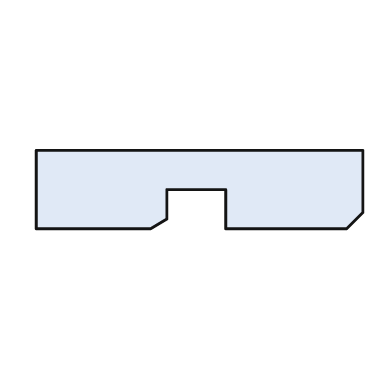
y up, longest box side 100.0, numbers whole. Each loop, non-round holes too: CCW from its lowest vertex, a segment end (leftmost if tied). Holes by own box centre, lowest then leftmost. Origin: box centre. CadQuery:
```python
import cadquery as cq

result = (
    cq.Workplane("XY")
    .moveTo(-50.0, -12.0)
    .lineTo(-15.0, -12.0)
    .lineTo(-10.0, -9.0)
    .lineTo(-10.0, 0.0)
    .lineTo(8.0, 0.0)
    .lineTo(8.0, -12.0)
    .lineTo(45.0, -12.0)
    .lineTo(50.0, -7.0)
    .lineTo(50.0, 12.0)
    .lineTo(-50.0, 12.0)
    .close()
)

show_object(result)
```